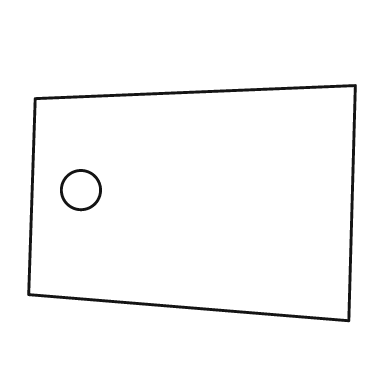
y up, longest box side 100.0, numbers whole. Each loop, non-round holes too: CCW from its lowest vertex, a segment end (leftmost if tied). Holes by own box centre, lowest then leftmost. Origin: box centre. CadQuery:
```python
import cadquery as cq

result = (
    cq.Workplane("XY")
    .moveTo(48.0, -36.0)
    .lineTo(50.0, 36.0)
    .lineTo(-48.0, 32.0)
    .lineTo(-50.0, -28.0)
    .close()
    .moveTo(-34.0, 4.0)
    .circle(6.0)
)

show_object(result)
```